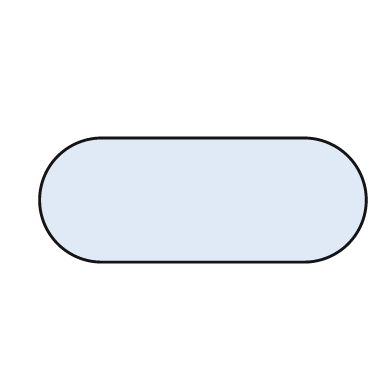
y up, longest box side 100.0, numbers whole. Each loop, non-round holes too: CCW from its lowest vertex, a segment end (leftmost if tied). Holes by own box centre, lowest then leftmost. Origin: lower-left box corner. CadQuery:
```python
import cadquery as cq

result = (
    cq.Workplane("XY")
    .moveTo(19.0, 0.0)
    .lineTo(81.0, 0.0)
    .threePointArc((100.0, 19.0), (81.0, 38.0))
    .lineTo(19.0, 38.0)
    .threePointArc((0.0, 19.0), (19.0, 0.0))
    .close()
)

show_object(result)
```